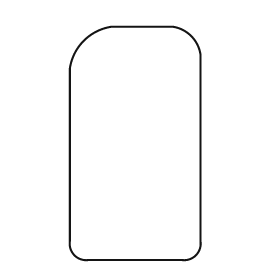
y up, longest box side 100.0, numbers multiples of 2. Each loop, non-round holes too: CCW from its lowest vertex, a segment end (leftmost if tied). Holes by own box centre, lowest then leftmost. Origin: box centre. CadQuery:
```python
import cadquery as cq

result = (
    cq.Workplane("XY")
    .moveTo(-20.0, -50.0)
    .lineTo(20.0, -50.0)
    .threePointArc((26.0, -48.0), (28.0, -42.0))
    .lineTo(28.0, 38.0)
    .threePointArc((24.0, 46.0), (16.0, 50.0))
    .lineTo(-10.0, 50.0)
    .threePointArc((-22.0, 44.0), (-28.0, 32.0))
    .lineTo(-28.0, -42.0)
    .threePointArc((-26.0, -48.0), (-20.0, -50.0))
    .close()
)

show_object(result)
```